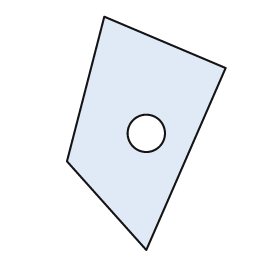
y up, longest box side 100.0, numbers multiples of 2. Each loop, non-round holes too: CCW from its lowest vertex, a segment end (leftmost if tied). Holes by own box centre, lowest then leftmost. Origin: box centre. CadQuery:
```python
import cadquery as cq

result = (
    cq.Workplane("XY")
    .moveTo(0.0, -50.0)
    .lineTo(34.0, 28.0)
    .lineTo(-18.0, 50.0)
    .lineTo(-34.0, -12.0)
    .close()
    .moveTo(0.0, 0.0)
    .circle(8.0)
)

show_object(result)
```